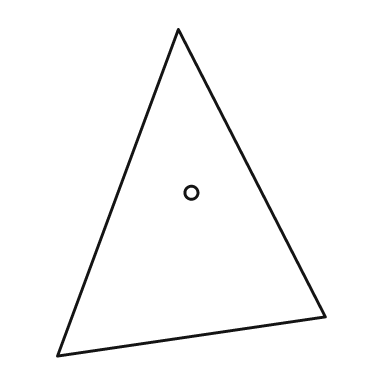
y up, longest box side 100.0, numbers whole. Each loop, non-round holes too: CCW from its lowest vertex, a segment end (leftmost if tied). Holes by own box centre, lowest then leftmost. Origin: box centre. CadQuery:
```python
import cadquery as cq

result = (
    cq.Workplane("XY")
    .moveTo(-41.0, -50.0)
    .lineTo(41.0, -38.0)
    .lineTo(-4.0, 50.0)
    .close()
    .moveTo(0.0, 0.0)
    .circle(2.0)
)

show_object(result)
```